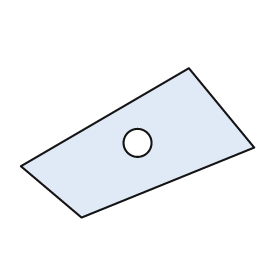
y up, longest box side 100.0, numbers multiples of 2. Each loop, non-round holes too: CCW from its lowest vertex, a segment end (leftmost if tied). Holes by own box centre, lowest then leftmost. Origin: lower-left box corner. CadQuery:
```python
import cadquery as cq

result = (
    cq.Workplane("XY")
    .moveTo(26.0, 0.0)
    .lineTo(100.0, 30.0)
    .lineTo(72.0, 64.0)
    .lineTo(0.0, 22.0)
    .close()
    .moveTo(50.0, 32.0)
    .circle(6.0)
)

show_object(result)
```